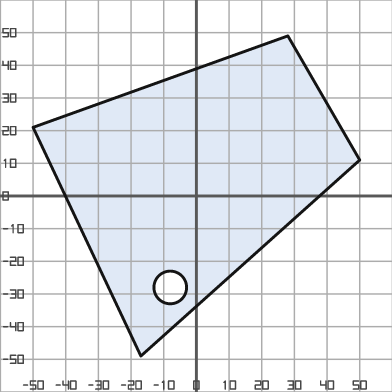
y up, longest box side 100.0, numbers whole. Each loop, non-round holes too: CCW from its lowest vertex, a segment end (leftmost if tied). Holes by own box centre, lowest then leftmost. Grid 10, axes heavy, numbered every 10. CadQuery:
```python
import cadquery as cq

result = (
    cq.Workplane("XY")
    .moveTo(-17.0, -49.0)
    .lineTo(50.0, 11.0)
    .lineTo(28.0, 49.0)
    .lineTo(-50.0, 21.0)
    .close()
    .moveTo(-8.0, -28.0)
    .circle(5.0)
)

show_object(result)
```